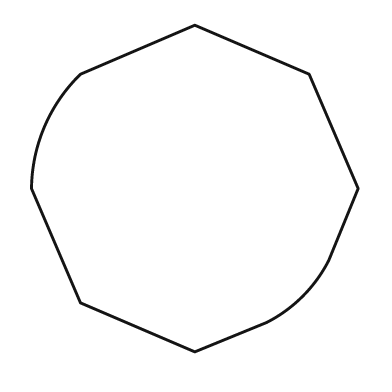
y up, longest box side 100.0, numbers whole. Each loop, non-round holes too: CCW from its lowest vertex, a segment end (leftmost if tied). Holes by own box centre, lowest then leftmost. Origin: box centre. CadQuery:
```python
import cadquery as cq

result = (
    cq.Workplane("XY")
    .moveTo(0.0, -50.0)
    .lineTo(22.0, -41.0)
    .threePointArc((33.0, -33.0), (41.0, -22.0))
    .lineTo(50.0, 0.0)
    .lineTo(35.0, 35.0)
    .lineTo(0.0, 50.0)
    .lineTo(-35.0, 35.0)
    .threePointArc((-46.0, 19.0), (-50.0, 0.0))
    .lineTo(-35.0, -35.0)
    .close()
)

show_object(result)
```